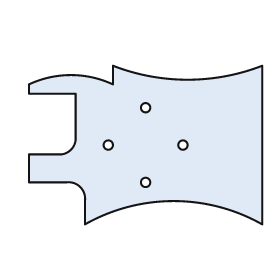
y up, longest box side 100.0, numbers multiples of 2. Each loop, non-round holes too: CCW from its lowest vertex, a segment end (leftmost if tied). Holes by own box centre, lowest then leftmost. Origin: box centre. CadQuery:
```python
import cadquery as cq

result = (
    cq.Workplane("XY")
    .moveTo(-26.0, -34.0)
    .threePointArc((12.0, -24.0), (50.0, -34.0))
    .lineTo(50.0, 34.0)
    .threePointArc((18.0, 28.0), (-14.0, 34.0))
    .lineTo(-14.0, 26.0)
    .threePointArc((-32.0, 30.0), (-50.0, 26.0))
    .lineTo(-50.0, 22.0)
    .lineTo(-30.0, 22.0)
    .lineTo(-30.0, 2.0)
    .threePointArc((-32.0, -2.0), (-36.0, -4.0))
    .lineTo(-50.0, -4.0)
    .lineTo(-50.0, -16.0)
    .lineTo(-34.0, -16.0)
    .threePointArc((-28.0, -18.0), (-26.0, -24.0))
    .close()
    .moveTo(0.0, -16.0)
    .circle(2.0)
    .moveTo(-16.0, 0.0)
    .circle(2.0)
    .moveTo(16.0, 0.0)
    .circle(2.0)
    .moveTo(0.0, 16.0)
    .circle(2.0)
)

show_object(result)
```